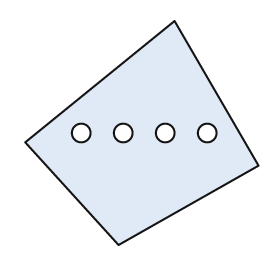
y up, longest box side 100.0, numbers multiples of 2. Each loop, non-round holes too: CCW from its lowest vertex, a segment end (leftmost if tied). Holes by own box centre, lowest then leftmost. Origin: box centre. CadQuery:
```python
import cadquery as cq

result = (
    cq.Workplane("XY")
    .moveTo(-10.0, -48.0)
    .lineTo(50.0, -14.0)
    .lineTo(14.0, 48.0)
    .lineTo(-50.0, -4.0)
    .close()
    .moveTo(-26.0, 0.0)
    .circle(4.0)
    .moveTo(-8.0, 0.0)
    .circle(4.0)
    .moveTo(10.0, 0.0)
    .circle(4.0)
    .moveTo(28.0, 0.0)
    .circle(4.0)
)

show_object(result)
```